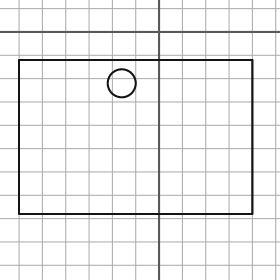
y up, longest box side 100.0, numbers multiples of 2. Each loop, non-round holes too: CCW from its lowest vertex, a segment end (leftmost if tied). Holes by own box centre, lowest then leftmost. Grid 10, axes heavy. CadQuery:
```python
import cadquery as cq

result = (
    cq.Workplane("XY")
    .moveTo(-60.0, -78.0)
    .lineTo(40.0, -78.0)
    .lineTo(40.0, -12.0)
    .lineTo(-60.0, -12.0)
    .close()
    .moveTo(-16.0, -22.0)
    .circle(6.0)
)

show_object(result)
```